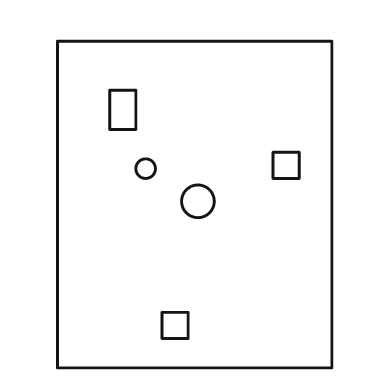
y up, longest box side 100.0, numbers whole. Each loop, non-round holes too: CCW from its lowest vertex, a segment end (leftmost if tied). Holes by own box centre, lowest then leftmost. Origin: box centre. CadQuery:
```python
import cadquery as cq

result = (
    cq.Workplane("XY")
    .moveTo(-42.0, -50.0)
    .lineTo(42.0, -50.0)
    .lineTo(42.0, 50.0)
    .lineTo(-42.0, 50.0)
    .close()
    .moveTo(-10.0, -41.0)
    .lineTo(-2.0, -41.0)
    .lineTo(-2.0, -33.0)
    .lineTo(-10.0, -33.0)
    .close()
    .moveTo(1.0, 1.0)
    .circle(5.0)
    .moveTo(-15.0, 11.0)
    .circle(3.0)
    .moveTo(24.0, 8.0)
    .lineTo(32.0, 8.0)
    .lineTo(32.0, 16.0)
    .lineTo(24.0, 16.0)
    .close()
    .moveTo(-26.0, 23.0)
    .lineTo(-18.0, 23.0)
    .lineTo(-18.0, 35.0)
    .lineTo(-26.0, 35.0)
    .close()
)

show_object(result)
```